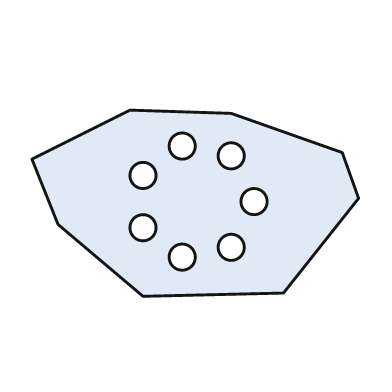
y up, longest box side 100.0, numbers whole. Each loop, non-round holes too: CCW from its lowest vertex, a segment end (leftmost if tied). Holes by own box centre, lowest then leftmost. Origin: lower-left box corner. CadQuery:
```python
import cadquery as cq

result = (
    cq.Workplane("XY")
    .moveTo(34.0, 0.0)
    .lineTo(77.0, 1.0)
    .lineTo(100.0, 30.0)
    .lineTo(95.0, 44.0)
    .lineTo(61.0, 56.0)
    .lineTo(30.0, 57.0)
    .lineTo(0.0, 42.0)
    .lineTo(8.0, 22.0)
    .close()
    .moveTo(46.0, 12.0)
    .circle(4.0)
    .moveTo(61.0, 15.0)
    .circle(4.0)
    .moveTo(34.0, 21.0)
    .circle(4.0)
    .moveTo(68.0, 29.0)
    .circle(4.0)
    .moveTo(34.0, 37.0)
    .circle(4.0)
    .moveTo(61.0, 43.0)
    .circle(4.0)
    .moveTo(46.0, 46.0)
    .circle(4.0)
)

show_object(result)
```